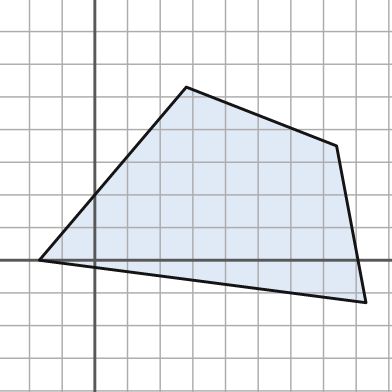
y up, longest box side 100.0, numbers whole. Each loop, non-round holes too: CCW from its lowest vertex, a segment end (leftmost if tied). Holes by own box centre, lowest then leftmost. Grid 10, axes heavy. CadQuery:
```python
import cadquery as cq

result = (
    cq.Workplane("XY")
    .moveTo(83.0, -13.0)
    .lineTo(74.0, 35.0)
    .lineTo(28.0, 53.0)
    .lineTo(-17.0, 0.0)
    .close()
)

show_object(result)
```